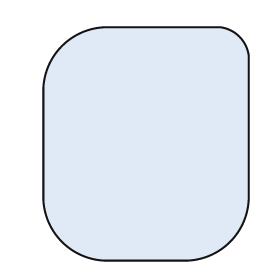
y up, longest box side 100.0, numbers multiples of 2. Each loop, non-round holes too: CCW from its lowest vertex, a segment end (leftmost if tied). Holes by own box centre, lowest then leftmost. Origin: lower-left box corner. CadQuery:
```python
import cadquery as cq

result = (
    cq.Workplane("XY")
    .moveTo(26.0, 0.0)
    .lineTo(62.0, 0.0)
    .threePointArc((80.0, 8.0), (88.0, 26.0))
    .lineTo(88.0, 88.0)
    .threePointArc((84.0, 96.0), (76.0, 100.0))
    .lineTo(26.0, 100.0)
    .threePointArc((8.0, 92.0), (0.0, 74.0))
    .lineTo(0.0, 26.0)
    .threePointArc((8.0, 8.0), (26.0, 0.0))
    .close()
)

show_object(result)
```